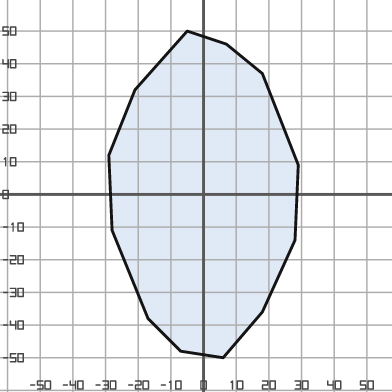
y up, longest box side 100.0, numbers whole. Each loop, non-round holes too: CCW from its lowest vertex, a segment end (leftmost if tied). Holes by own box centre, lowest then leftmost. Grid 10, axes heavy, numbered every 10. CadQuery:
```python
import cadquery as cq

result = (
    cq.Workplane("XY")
    .moveTo(6.0, -50.0)
    .lineTo(18.0, -36.0)
    .lineTo(28.0, -14.0)
    .lineTo(29.0, 9.0)
    .lineTo(18.0, 37.0)
    .lineTo(7.0, 46.0)
    .lineTo(-5.0, 50.0)
    .lineTo(-21.0, 32.0)
    .lineTo(-29.0, 12.0)
    .lineTo(-28.0, -11.0)
    .lineTo(-17.0, -38.0)
    .lineTo(-7.0, -48.0)
    .close()
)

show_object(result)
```